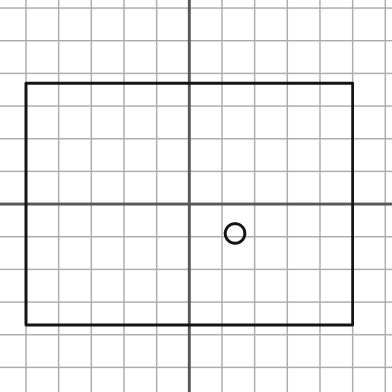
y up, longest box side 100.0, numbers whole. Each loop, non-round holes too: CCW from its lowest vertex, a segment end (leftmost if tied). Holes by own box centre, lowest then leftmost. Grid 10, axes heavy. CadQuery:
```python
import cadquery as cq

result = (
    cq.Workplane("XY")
    .moveTo(-50.0, -37.0)
    .lineTo(50.0, -37.0)
    .lineTo(50.0, 37.0)
    .lineTo(-50.0, 37.0)
    .close()
    .moveTo(14.0, -9.0)
    .circle(3.0)
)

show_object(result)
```